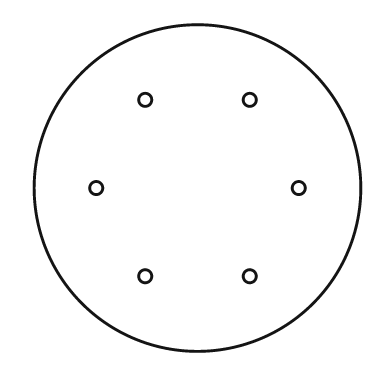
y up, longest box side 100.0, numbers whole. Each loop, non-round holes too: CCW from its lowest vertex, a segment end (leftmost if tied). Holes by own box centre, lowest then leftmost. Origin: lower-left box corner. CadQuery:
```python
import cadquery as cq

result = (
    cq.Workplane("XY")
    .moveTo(50.0, 50.0)
    .circle(50.0)
    .moveTo(34.0, 23.0)
    .circle(2.0)
    .moveTo(66.0, 23.0)
    .circle(2.0)
    .moveTo(19.0, 50.0)
    .circle(2.0)
    .moveTo(81.0, 50.0)
    .circle(2.0)
    .moveTo(34.0, 77.0)
    .circle(2.0)
    .moveTo(66.0, 77.0)
    .circle(2.0)
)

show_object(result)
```